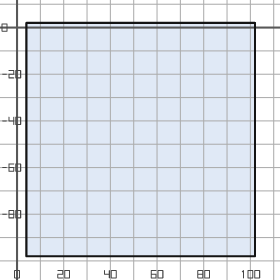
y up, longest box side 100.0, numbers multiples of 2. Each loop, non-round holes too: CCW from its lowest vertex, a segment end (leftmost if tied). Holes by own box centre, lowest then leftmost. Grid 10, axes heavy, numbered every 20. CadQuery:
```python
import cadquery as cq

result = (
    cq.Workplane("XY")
    .moveTo(4.0, -98.0)
    .lineTo(102.0, -98.0)
    .lineTo(102.0, 2.0)
    .lineTo(4.0, 2.0)
    .close()
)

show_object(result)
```